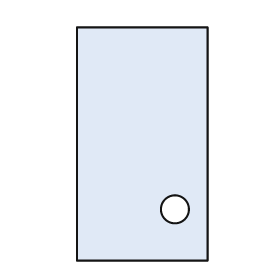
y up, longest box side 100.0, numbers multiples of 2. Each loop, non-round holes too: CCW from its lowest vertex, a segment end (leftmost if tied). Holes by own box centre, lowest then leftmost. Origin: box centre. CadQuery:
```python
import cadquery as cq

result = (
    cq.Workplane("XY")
    .moveTo(-28.0, -50.0)
    .lineTo(28.0, -50.0)
    .lineTo(28.0, 50.0)
    .lineTo(-28.0, 50.0)
    .close()
    .moveTo(14.0, -28.0)
    .circle(6.0)
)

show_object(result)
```